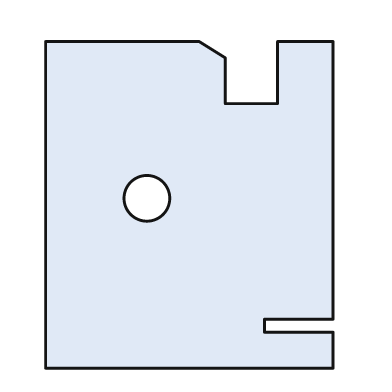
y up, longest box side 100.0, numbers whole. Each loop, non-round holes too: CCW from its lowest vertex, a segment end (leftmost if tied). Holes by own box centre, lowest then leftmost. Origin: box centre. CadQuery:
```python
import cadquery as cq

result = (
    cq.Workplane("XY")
    .moveTo(-44.0, -50.0)
    .lineTo(44.0, -50.0)
    .lineTo(44.0, -39.0)
    .lineTo(23.0, -39.0)
    .lineTo(23.0, -35.0)
    .lineTo(44.0, -35.0)
    .lineTo(44.0, 50.0)
    .lineTo(27.0, 50.0)
    .lineTo(27.0, 31.0)
    .lineTo(11.0, 31.0)
    .lineTo(11.0, 45.0)
    .lineTo(3.0, 50.0)
    .lineTo(-44.0, 50.0)
    .close()
    .moveTo(-13.0, 2.0)
    .circle(7.0)
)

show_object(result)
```